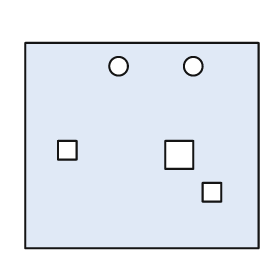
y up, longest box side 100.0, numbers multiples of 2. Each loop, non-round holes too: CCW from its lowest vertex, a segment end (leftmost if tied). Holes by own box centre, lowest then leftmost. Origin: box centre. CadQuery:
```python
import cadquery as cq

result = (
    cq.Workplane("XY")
    .moveTo(-50.0, -44.0)
    .lineTo(50.0, -44.0)
    .lineTo(50.0, 44.0)
    .lineTo(-50.0, 44.0)
    .close()
    .moveTo(26.0, -24.0)
    .lineTo(34.0, -24.0)
    .lineTo(34.0, -16.0)
    .lineTo(26.0, -16.0)
    .close()
    .moveTo(10.0, -10.0)
    .lineTo(22.0, -10.0)
    .lineTo(22.0, 2.0)
    .lineTo(10.0, 2.0)
    .close()
    .moveTo(-36.0, -6.0)
    .lineTo(-28.0, -6.0)
    .lineTo(-28.0, 2.0)
    .lineTo(-36.0, 2.0)
    .close()
    .moveTo(-10.0, 34.0)
    .circle(4.0)
    .moveTo(22.0, 34.0)
    .circle(4.0)
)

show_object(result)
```